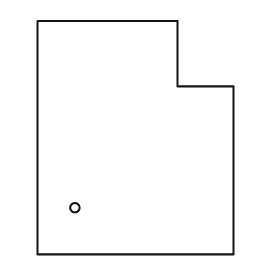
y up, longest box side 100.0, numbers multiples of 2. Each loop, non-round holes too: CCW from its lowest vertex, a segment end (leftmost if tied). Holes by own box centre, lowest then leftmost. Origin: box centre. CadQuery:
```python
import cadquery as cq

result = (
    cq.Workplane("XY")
    .moveTo(-42.0, -50.0)
    .lineTo(42.0, -50.0)
    .lineTo(42.0, 22.0)
    .lineTo(18.0, 22.0)
    .lineTo(18.0, 50.0)
    .lineTo(-42.0, 50.0)
    .close()
    .moveTo(-26.0, -30.0)
    .circle(2.0)
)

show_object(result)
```